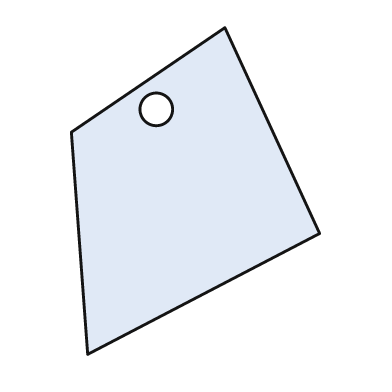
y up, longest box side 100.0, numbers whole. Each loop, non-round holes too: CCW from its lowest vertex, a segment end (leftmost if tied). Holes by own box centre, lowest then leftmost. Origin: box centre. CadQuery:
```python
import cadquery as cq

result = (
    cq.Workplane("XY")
    .moveTo(-33.0, -50.0)
    .lineTo(38.0, -13.0)
    .lineTo(9.0, 50.0)
    .lineTo(-38.0, 18.0)
    .close()
    .moveTo(-12.0, 25.0)
    .circle(5.0)
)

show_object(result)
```